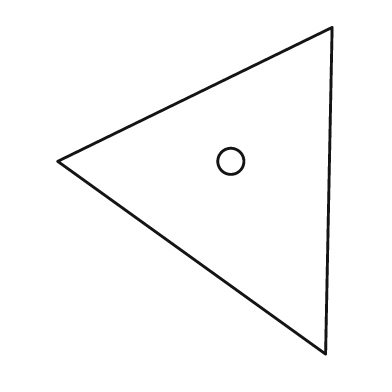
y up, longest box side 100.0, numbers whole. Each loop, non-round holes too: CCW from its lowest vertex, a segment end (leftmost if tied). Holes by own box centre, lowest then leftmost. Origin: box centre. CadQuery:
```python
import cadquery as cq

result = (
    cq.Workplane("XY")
    .moveTo(40.0, -50.0)
    .lineTo(42.0, 50.0)
    .lineTo(-42.0, 9.0)
    .close()
    .moveTo(11.0, 9.0)
    .circle(4.0)
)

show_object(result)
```